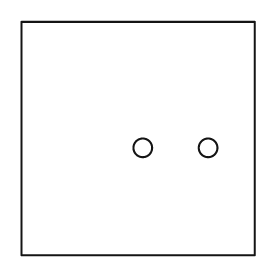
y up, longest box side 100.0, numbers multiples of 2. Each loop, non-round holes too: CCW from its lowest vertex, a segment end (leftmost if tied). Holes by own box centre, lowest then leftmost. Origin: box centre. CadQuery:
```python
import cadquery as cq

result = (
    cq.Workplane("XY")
    .moveTo(-50.0, -50.0)
    .lineTo(50.0, -50.0)
    .lineTo(50.0, 50.0)
    .lineTo(-50.0, 50.0)
    .close()
    .moveTo(2.0, -4.0)
    .circle(4.0)
    .moveTo(30.0, -4.0)
    .circle(4.0)
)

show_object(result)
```